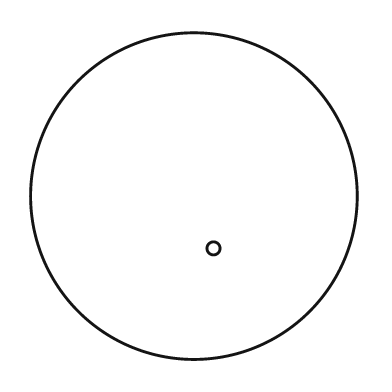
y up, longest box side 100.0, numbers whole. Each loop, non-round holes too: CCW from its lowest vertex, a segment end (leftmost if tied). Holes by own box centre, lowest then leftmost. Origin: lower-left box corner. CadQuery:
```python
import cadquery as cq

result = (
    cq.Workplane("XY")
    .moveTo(50.0, 50.0)
    .circle(50.0)
    .moveTo(56.0, 34.0)
    .circle(2.0)
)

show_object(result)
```